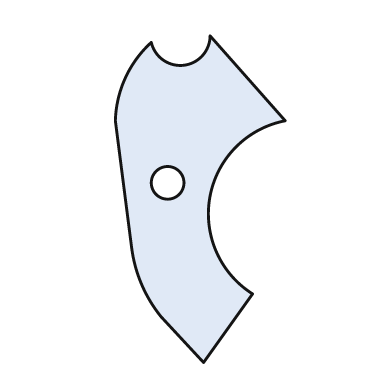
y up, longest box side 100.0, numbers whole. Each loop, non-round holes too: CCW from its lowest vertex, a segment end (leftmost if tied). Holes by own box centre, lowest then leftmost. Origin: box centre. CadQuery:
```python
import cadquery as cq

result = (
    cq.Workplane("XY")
    .moveTo(1.0, -50.0)
    .lineTo(16.0, -29.0)
    .threePointArc((3.0, 1.0), (26.0, 24.0))
    .lineTo(3.0, 50.0)
    .threePointArc((-5.0, 41.0), (-15.0, 48.0))
    .threePointArc((-23.0, 37.0), (-26.0, 24.0))
    .lineTo(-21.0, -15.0)
    .threePointArc((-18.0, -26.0), (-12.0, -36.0))
    .close()
    .moveTo(-10.0, 5.0)
    .circle(5.0)
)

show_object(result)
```